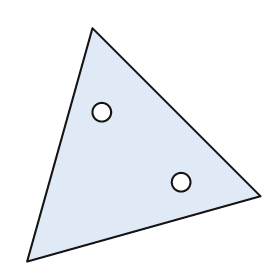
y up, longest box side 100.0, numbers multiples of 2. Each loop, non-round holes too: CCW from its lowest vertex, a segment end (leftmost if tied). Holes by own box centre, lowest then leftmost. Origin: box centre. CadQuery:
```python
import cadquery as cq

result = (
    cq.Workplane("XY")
    .moveTo(-50.0, -50.0)
    .lineTo(50.0, -22.0)
    .lineTo(-22.0, 50.0)
    .close()
    .moveTo(16.0, -16.0)
    .circle(4.0)
    .moveTo(-18.0, 14.0)
    .circle(4.0)
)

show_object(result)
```